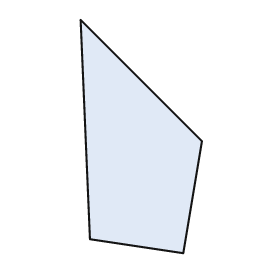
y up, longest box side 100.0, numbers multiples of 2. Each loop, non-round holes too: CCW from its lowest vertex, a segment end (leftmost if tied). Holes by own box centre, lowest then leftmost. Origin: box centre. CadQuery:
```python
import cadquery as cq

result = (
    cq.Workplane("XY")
    .moveTo(18.0, -50.0)
    .lineTo(26.0, -2.0)
    .lineTo(-26.0, 50.0)
    .lineTo(-22.0, -44.0)
    .close()
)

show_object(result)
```